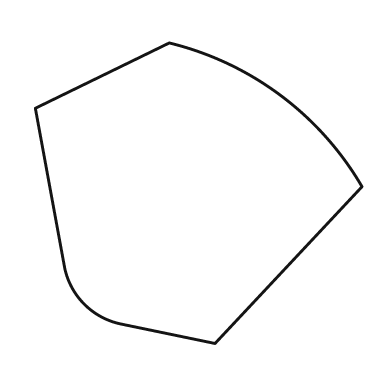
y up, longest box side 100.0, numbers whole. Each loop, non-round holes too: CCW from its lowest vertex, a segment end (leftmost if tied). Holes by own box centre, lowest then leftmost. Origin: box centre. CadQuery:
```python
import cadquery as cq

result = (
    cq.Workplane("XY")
    .moveTo(5.0, -46.0)
    .lineTo(50.0, 2.0)
    .threePointArc((25.0, 30.0), (-9.0, 46.0))
    .lineTo(-50.0, 26.0)
    .lineTo(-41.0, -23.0)
    .threePointArc((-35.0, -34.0), (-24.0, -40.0))
    .close()
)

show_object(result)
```